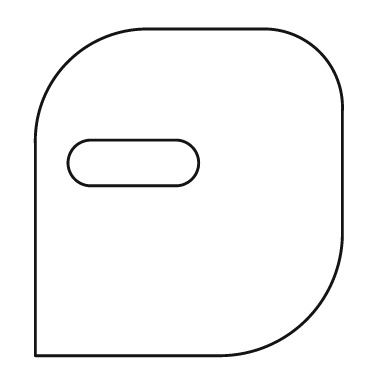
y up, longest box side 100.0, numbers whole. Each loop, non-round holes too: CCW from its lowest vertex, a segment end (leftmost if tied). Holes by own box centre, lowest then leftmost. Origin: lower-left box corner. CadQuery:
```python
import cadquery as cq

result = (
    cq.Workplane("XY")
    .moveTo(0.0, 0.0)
    .lineTo(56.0, 0.0)
    .threePointArc((83.0, 11.0), (94.0, 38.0))
    .lineTo(94.0, 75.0)
    .threePointArc((87.0, 93.0), (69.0, 100.0))
    .lineTo(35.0, 100.0)
    .threePointArc((10.0, 90.0), (0.0, 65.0))
    .close()
    .moveTo(17.0, 52.0)
    .lineTo(43.0, 52.0)
    .threePointArc((50.0, 59.0), (43.0, 66.0))
    .lineTo(17.0, 66.0)
    .threePointArc((10.0, 59.0), (17.0, 52.0))
    .close()
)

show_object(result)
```